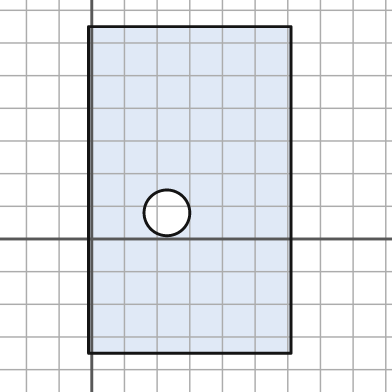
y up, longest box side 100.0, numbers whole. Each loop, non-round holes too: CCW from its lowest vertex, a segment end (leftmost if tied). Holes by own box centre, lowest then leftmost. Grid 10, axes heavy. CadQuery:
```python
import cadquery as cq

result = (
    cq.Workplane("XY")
    .moveTo(-1.0, -35.0)
    .lineTo(61.0, -35.0)
    .lineTo(61.0, 65.0)
    .lineTo(-1.0, 65.0)
    .close()
    .moveTo(23.0, 8.0)
    .circle(7.0)
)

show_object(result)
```